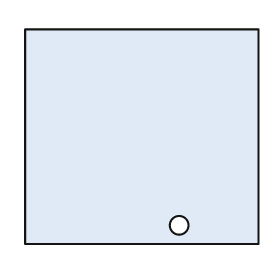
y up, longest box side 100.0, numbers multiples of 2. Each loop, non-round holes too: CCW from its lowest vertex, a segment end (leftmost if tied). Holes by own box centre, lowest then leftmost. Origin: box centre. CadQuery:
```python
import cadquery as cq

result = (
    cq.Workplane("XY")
    .moveTo(-50.0, -46.0)
    .lineTo(50.0, -46.0)
    .lineTo(50.0, 46.0)
    .lineTo(-50.0, 46.0)
    .close()
    .moveTo(16.0, -38.0)
    .circle(4.0)
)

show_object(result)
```